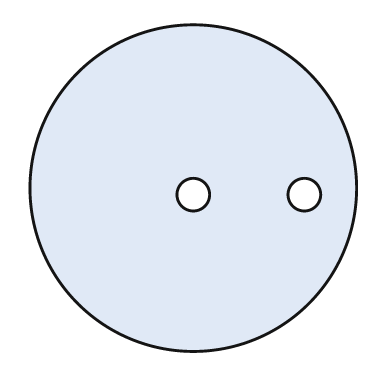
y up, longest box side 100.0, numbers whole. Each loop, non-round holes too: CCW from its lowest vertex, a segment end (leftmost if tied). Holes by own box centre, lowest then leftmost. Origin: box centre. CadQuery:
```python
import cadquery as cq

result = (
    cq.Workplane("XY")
    .moveTo(0.0, 0.0)
    .circle(50.0)
    .moveTo(0.0, -2.0)
    .circle(5.0)
    .moveTo(34.0, -2.0)
    .circle(5.0)
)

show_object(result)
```